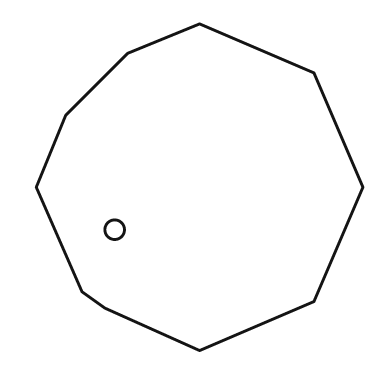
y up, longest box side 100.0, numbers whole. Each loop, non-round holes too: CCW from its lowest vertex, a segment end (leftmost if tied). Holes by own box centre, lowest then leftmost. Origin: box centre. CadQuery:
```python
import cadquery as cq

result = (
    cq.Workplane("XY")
    .moveTo(0.0, -50.0)
    .lineTo(35.0, -35.0)
    .lineTo(50.0, 0.0)
    .lineTo(35.0, 35.0)
    .lineTo(0.0, 50.0)
    .lineTo(-22.0, 41.0)
    .lineTo(-41.0, 22.0)
    .lineTo(-50.0, 0.0)
    .lineTo(-36.0, -32.0)
    .lineTo(-29.0, -37.0)
    .close()
    .moveTo(-26.0, -13.0)
    .circle(3.0)
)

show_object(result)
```